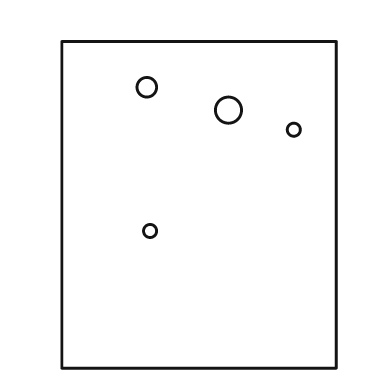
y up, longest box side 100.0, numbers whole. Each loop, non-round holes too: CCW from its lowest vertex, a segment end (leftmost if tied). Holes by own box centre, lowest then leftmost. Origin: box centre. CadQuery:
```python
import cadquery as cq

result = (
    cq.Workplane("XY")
    .moveTo(-42.0, -50.0)
    .lineTo(42.0, -50.0)
    .lineTo(42.0, 50.0)
    .lineTo(-42.0, 50.0)
    .close()
    .moveTo(-15.0, -8.0)
    .circle(2.0)
    .moveTo(29.0, 23.0)
    .circle(2.0)
    .moveTo(9.0, 29.0)
    .circle(4.0)
    .moveTo(-16.0, 36.0)
    .circle(3.0)
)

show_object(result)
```